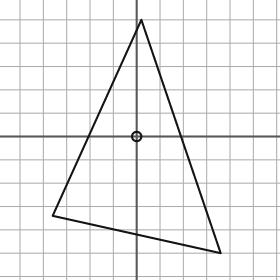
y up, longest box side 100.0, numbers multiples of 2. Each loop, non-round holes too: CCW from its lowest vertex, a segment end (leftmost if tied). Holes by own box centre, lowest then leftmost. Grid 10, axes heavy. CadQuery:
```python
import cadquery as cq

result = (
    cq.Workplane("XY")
    .moveTo(36.0, -50.0)
    .lineTo(2.0, 50.0)
    .lineTo(-36.0, -34.0)
    .close()
    .moveTo(0.0, 0.0)
    .circle(2.0)
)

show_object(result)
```